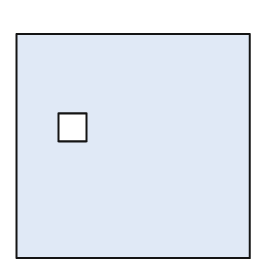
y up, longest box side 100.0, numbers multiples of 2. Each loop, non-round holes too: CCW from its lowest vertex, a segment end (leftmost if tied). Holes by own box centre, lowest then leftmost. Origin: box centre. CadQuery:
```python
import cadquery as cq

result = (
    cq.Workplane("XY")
    .moveTo(-50.0, -48.0)
    .lineTo(50.0, -48.0)
    .lineTo(50.0, 48.0)
    .lineTo(-50.0, 48.0)
    .close()
    .moveTo(-32.0, 2.0)
    .lineTo(-20.0, 2.0)
    .lineTo(-20.0, 14.0)
    .lineTo(-32.0, 14.0)
    .close()
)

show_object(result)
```